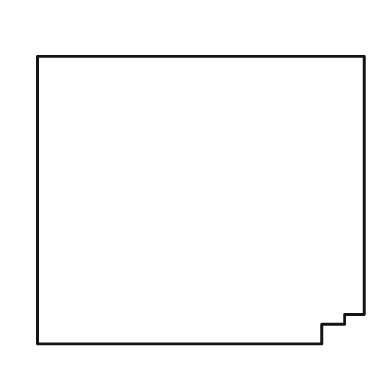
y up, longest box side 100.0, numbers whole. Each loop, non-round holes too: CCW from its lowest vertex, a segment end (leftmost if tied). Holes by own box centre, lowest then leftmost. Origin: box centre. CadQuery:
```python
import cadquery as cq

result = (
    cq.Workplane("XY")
    .moveTo(-50.0, -44.0)
    .lineTo(37.0, -44.0)
    .lineTo(37.0, -38.0)
    .lineTo(44.0, -38.0)
    .lineTo(44.0, -35.0)
    .lineTo(50.0, -35.0)
    .lineTo(50.0, 44.0)
    .lineTo(-50.0, 44.0)
    .close()
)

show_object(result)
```